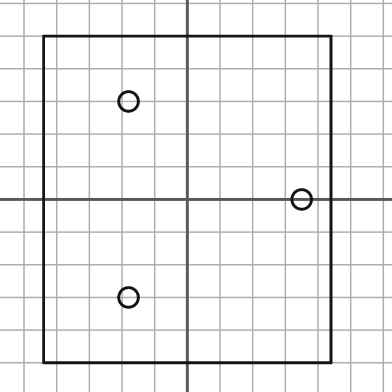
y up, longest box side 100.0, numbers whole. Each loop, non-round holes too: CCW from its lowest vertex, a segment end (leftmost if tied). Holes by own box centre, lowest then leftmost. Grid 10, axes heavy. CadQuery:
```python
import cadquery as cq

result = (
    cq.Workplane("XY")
    .moveTo(-44.0, -50.0)
    .lineTo(44.0, -50.0)
    .lineTo(44.0, 50.0)
    .lineTo(-44.0, 50.0)
    .close()
    .moveTo(-18.0, -30.0)
    .circle(3.0)
    .moveTo(35.0, 0.0)
    .circle(3.0)
    .moveTo(-18.0, 30.0)
    .circle(3.0)
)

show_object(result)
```